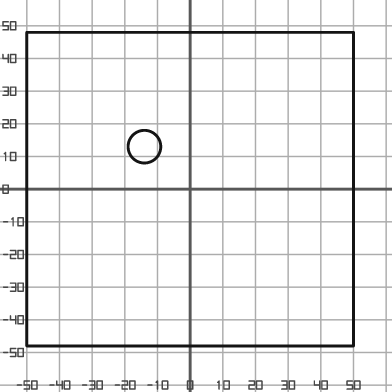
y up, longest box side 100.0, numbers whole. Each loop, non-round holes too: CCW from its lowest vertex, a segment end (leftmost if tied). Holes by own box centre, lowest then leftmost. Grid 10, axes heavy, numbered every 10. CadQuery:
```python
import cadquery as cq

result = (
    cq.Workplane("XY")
    .moveTo(-50.0, -48.0)
    .lineTo(50.0, -48.0)
    .lineTo(50.0, 48.0)
    .lineTo(-50.0, 48.0)
    .close()
    .moveTo(-14.0, 13.0)
    .circle(5.0)
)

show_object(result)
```